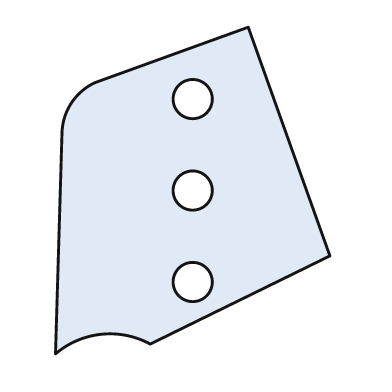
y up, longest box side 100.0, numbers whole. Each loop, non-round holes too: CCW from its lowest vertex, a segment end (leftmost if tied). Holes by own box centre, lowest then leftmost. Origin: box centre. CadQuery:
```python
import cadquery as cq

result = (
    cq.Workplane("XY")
    .moveTo(-42.0, -50.0)
    .threePointArc((-28.0, -44.0), (-13.0, -47.0))
    .lineTo(42.0, -20.0)
    .lineTo(17.0, 50.0)
    .lineTo(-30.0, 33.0)
    .threePointArc((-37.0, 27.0), (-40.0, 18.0))
    .close()
    .moveTo(0.0, -28.0)
    .circle(6.0)
    .moveTo(0.0, 0.0)
    .circle(6.0)
    .moveTo(0.0, 28.0)
    .circle(6.0)
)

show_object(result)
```